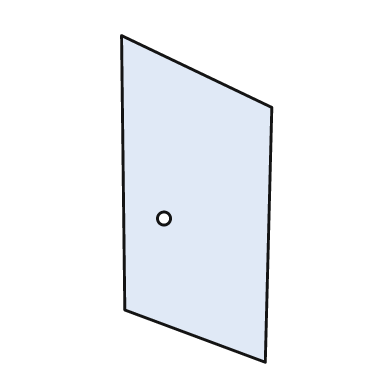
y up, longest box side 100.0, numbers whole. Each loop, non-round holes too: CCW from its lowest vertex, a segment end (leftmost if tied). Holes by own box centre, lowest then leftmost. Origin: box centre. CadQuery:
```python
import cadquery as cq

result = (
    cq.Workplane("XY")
    .moveTo(21.0, -50.0)
    .lineTo(23.0, 28.0)
    .lineTo(-23.0, 50.0)
    .lineTo(-22.0, -34.0)
    .close()
    .moveTo(-10.0, -6.0)
    .circle(2.0)
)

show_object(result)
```